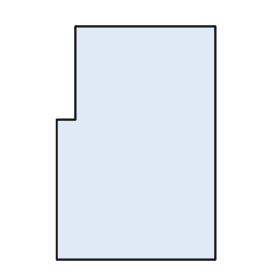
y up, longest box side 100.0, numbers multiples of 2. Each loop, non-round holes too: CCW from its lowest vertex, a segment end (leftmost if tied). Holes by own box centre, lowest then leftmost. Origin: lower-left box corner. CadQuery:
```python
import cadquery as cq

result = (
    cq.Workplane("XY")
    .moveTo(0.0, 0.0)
    .lineTo(68.0, 0.0)
    .lineTo(68.0, 100.0)
    .lineTo(8.0, 100.0)
    .lineTo(8.0, 60.0)
    .lineTo(0.0, 60.0)
    .close()
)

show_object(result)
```